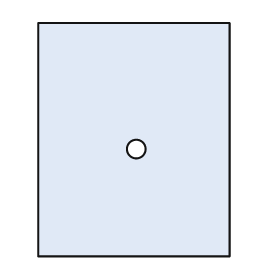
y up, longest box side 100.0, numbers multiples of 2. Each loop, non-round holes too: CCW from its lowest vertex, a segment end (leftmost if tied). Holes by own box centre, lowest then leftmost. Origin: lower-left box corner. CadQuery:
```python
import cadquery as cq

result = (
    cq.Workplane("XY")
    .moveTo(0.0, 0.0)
    .lineTo(82.0, 0.0)
    .lineTo(82.0, 100.0)
    .lineTo(0.0, 100.0)
    .close()
    .moveTo(42.0, 46.0)
    .circle(4.0)
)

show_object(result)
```